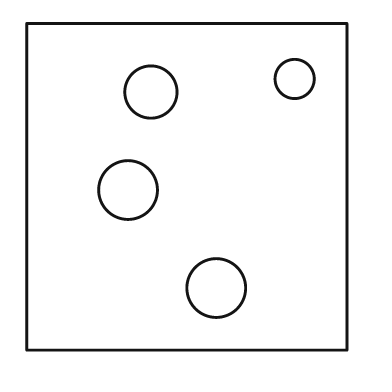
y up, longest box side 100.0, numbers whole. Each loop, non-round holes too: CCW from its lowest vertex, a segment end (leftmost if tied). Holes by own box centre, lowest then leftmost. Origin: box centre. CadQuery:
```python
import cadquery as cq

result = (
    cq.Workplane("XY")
    .moveTo(-49.0, -50.0)
    .lineTo(49.0, -50.0)
    .lineTo(49.0, 50.0)
    .lineTo(-49.0, 50.0)
    .close()
    .moveTo(9.0, -31.0)
    .circle(9.0)
    .moveTo(-18.0, -1.0)
    .circle(9.0)
    .moveTo(-11.0, 29.0)
    .circle(8.0)
    .moveTo(33.0, 33.0)
    .circle(6.0)
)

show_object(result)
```